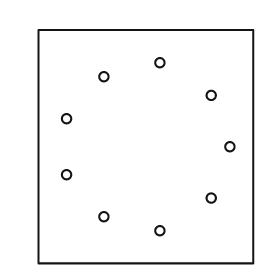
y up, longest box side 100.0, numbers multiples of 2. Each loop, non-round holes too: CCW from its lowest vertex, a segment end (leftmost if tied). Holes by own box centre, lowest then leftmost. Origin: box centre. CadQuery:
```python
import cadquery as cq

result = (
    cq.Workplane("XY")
    .moveTo(-46.0, -50.0)
    .lineTo(46.0, -50.0)
    .lineTo(46.0, 50.0)
    .lineTo(-46.0, 50.0)
    .close()
    .moveTo(6.0, -36.0)
    .circle(2.0)
    .moveTo(-18.0, -30.0)
    .circle(2.0)
    .moveTo(28.0, -22.0)
    .circle(2.0)
    .moveTo(-34.0, -12.0)
    .circle(2.0)
    .moveTo(36.0, 0.0)
    .circle(2.0)
    .moveTo(-34.0, 12.0)
    .circle(2.0)
    .moveTo(28.0, 22.0)
    .circle(2.0)
    .moveTo(-18.0, 30.0)
    .circle(2.0)
    .moveTo(6.0, 36.0)
    .circle(2.0)
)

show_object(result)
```